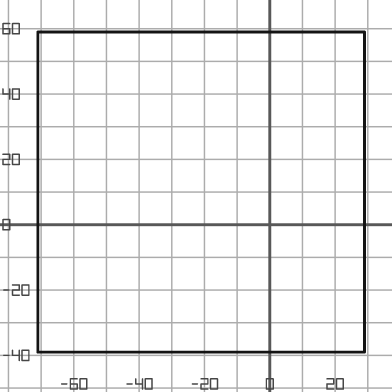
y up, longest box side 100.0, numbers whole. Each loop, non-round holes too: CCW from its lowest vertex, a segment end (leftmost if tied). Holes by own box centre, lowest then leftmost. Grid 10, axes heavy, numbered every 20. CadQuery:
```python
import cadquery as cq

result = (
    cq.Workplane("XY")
    .moveTo(-71.0, -39.0)
    .lineTo(29.0, -39.0)
    .lineTo(29.0, 59.0)
    .lineTo(-71.0, 59.0)
    .close()
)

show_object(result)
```